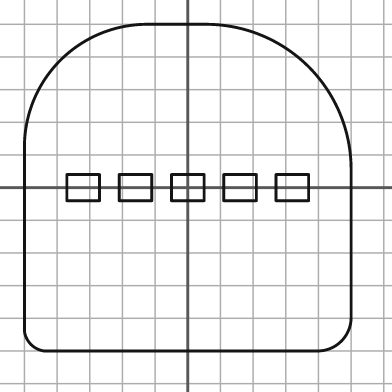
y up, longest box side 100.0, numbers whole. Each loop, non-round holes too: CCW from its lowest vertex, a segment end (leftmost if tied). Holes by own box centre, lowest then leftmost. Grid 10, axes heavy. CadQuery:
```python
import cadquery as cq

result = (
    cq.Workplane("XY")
    .moveTo(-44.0, -50.0)
    .lineTo(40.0, -50.0)
    .threePointArc((47.0, -47.0), (50.0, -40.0))
    .lineTo(50.0, 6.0)
    .threePointArc((37.0, 37.0), (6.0, 50.0))
    .lineTo(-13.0, 50.0)
    .threePointArc((-39.0, 39.0), (-50.0, 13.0))
    .lineTo(-50.0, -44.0)
    .threePointArc((-48.0, -48.0), (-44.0, -50.0))
    .close()
    .moveTo(-37.0, -4.0)
    .lineTo(-27.0, -4.0)
    .lineTo(-27.0, 4.0)
    .lineTo(-37.0, 4.0)
    .close()
    .moveTo(-21.0, -4.0)
    .lineTo(-11.0, -4.0)
    .lineTo(-11.0, 4.0)
    .lineTo(-21.0, 4.0)
    .close()
    .moveTo(-5.0, -4.0)
    .lineTo(5.0, -4.0)
    .lineTo(5.0, 4.0)
    .lineTo(-5.0, 4.0)
    .close()
    .moveTo(11.0, -4.0)
    .lineTo(21.0, -4.0)
    .lineTo(21.0, 4.0)
    .lineTo(11.0, 4.0)
    .close()
    .moveTo(27.0, -4.0)
    .lineTo(37.0, -4.0)
    .lineTo(37.0, 4.0)
    .lineTo(27.0, 4.0)
    .close()
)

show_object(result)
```